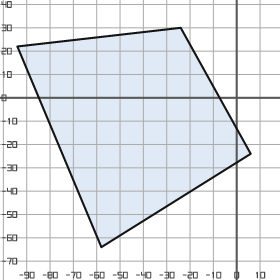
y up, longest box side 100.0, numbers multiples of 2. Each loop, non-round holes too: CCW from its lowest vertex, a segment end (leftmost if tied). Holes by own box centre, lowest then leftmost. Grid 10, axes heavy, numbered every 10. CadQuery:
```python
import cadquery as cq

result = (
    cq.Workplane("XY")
    .moveTo(-58.0, -64.0)
    .lineTo(6.0, -24.0)
    .lineTo(-24.0, 30.0)
    .lineTo(-94.0, 22.0)
    .close()
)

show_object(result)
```